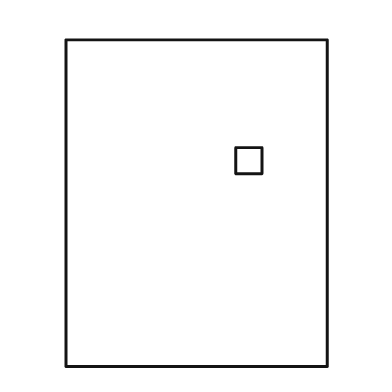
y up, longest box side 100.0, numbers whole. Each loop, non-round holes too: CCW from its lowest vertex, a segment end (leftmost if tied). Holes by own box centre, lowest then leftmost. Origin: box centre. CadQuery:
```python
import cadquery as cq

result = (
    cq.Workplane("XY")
    .moveTo(-40.0, -50.0)
    .lineTo(40.0, -50.0)
    .lineTo(40.0, 50.0)
    .lineTo(-40.0, 50.0)
    .close()
    .moveTo(12.0, 9.0)
    .lineTo(20.0, 9.0)
    .lineTo(20.0, 17.0)
    .lineTo(12.0, 17.0)
    .close()
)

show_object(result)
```